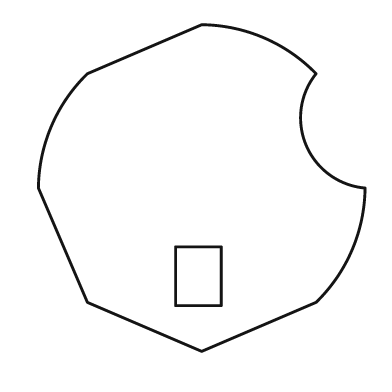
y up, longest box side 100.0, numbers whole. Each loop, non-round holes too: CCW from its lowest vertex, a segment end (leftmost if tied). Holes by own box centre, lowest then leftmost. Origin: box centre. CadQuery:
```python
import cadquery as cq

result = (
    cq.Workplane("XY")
    .moveTo(0.0, -50.0)
    .lineTo(35.0, -35.0)
    .threePointArc((46.0, -19.0), (50.0, 0.0))
    .threePointArc((32.0, 13.0), (35.0, 35.0))
    .threePointArc((19.0, 46.0), (0.0, 50.0))
    .lineTo(-35.0, 35.0)
    .threePointArc((-46.0, 19.0), (-50.0, 0.0))
    .lineTo(-35.0, -35.0)
    .close()
    .moveTo(-8.0, -36.0)
    .lineTo(6.0, -36.0)
    .lineTo(6.0, -18.0)
    .lineTo(-8.0, -18.0)
    .close()
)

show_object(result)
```